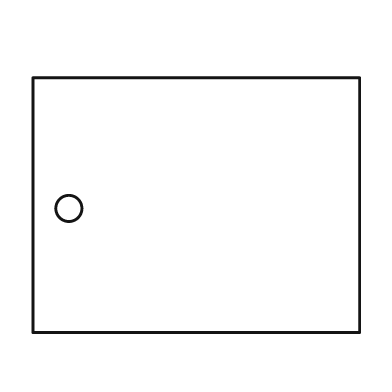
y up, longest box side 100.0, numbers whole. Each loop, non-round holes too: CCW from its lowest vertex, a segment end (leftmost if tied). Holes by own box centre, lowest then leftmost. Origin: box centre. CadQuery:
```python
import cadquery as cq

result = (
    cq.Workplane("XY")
    .moveTo(-50.0, -39.0)
    .lineTo(50.0, -39.0)
    .lineTo(50.0, 39.0)
    .lineTo(-50.0, 39.0)
    .close()
    .moveTo(-39.0, -1.0)
    .circle(4.0)
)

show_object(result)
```